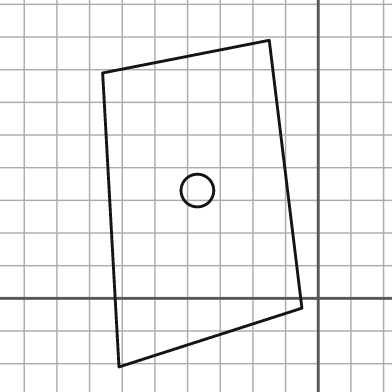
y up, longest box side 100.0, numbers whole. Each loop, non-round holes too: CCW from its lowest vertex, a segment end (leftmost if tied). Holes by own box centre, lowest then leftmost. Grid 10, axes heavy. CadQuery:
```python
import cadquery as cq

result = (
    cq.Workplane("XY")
    .moveTo(-61.0, -21.0)
    .lineTo(-5.0, -3.0)
    .lineTo(-15.0, 79.0)
    .lineTo(-66.0, 69.0)
    .close()
    .moveTo(-37.0, 33.0)
    .circle(5.0)
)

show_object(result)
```